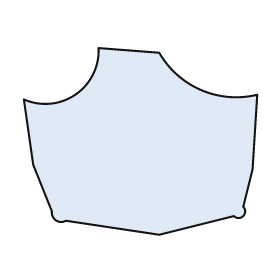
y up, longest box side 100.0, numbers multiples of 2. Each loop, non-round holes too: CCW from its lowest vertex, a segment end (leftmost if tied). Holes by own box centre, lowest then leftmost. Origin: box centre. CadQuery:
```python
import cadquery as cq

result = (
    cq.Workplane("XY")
    .moveTo(8.0, -40.0)
    .lineTo(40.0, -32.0)
    .threePointArc((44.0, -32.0), (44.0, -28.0))
    .lineTo(48.0, -12.0)
    .lineTo(50.0, 20.0)
    .threePointArc((26.0, 22.0), (8.0, 38.0))
    .lineTo(-18.0, 40.0)
    .threePointArc((-28.0, 20.0), (-50.0, 18.0))
    .lineTo(-46.0, -10.0)
    .lineTo(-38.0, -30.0)
    .threePointArc((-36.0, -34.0), (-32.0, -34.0))
    .close()
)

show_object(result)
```